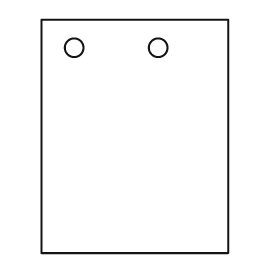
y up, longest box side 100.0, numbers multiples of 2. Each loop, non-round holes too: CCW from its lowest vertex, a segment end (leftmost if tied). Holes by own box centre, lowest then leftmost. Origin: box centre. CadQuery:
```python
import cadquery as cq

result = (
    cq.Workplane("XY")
    .moveTo(-40.0, -50.0)
    .lineTo(40.0, -50.0)
    .lineTo(40.0, 50.0)
    .lineTo(-40.0, 50.0)
    .close()
    .moveTo(-26.0, 38.0)
    .circle(4.0)
    .moveTo(10.0, 38.0)
    .circle(4.0)
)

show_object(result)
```